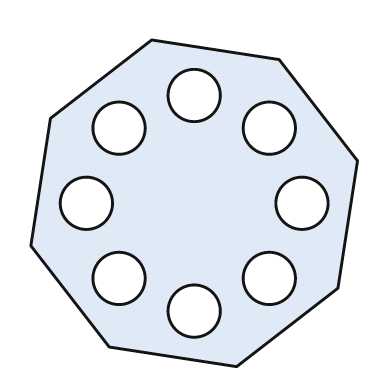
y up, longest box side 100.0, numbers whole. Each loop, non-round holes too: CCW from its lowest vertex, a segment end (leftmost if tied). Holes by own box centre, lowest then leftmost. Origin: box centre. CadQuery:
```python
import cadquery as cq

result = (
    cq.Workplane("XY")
    .moveTo(13.0, -50.0)
    .lineTo(44.0, -26.0)
    .lineTo(50.0, 13.0)
    .lineTo(26.0, 44.0)
    .lineTo(-13.0, 50.0)
    .lineTo(-44.0, 26.0)
    .lineTo(-50.0, -13.0)
    .lineTo(-26.0, -44.0)
    .close()
    .moveTo(0.0, -33.0)
    .circle(8.0)
    .moveTo(-23.0, -23.0)
    .circle(8.0)
    .moveTo(23.0, -23.0)
    .circle(8.0)
    .moveTo(-33.0, 0.0)
    .circle(8.0)
    .moveTo(33.0, 0.0)
    .circle(8.0)
    .moveTo(-23.0, 23.0)
    .circle(8.0)
    .moveTo(23.0, 23.0)
    .circle(8.0)
    .moveTo(0.0, 33.0)
    .circle(8.0)
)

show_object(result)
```